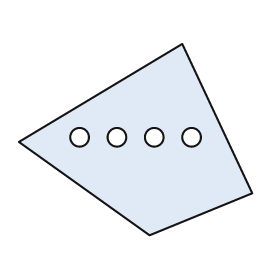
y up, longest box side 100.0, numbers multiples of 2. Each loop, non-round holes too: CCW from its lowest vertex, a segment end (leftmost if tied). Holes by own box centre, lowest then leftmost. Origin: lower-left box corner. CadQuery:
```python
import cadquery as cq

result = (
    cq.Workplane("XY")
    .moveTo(56.0, 0.0)
    .lineTo(100.0, 18.0)
    .lineTo(70.0, 82.0)
    .lineTo(0.0, 40.0)
    .close()
    .moveTo(26.0, 42.0)
    .circle(4.0)
    .moveTo(42.0, 42.0)
    .circle(4.0)
    .moveTo(58.0, 42.0)
    .circle(4.0)
    .moveTo(74.0, 42.0)
    .circle(4.0)
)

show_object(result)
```